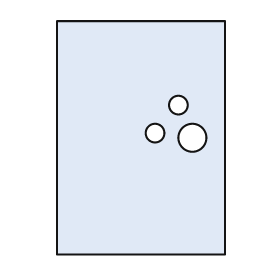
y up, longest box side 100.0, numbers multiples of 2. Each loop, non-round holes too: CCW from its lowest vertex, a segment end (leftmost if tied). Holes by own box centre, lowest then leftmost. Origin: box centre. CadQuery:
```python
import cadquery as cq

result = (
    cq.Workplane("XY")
    .moveTo(-36.0, -50.0)
    .lineTo(36.0, -50.0)
    .lineTo(36.0, 50.0)
    .lineTo(-36.0, 50.0)
    .close()
    .moveTo(22.0, 0.0)
    .circle(6.0)
    .moveTo(6.0, 2.0)
    .circle(4.0)
    .moveTo(16.0, 14.0)
    .circle(4.0)
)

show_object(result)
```